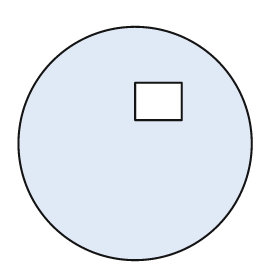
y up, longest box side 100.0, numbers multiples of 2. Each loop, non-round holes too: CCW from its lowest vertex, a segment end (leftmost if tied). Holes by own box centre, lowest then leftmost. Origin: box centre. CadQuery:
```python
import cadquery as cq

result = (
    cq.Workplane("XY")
    .moveTo(0.0, 0.0)
    .circle(50.0)
    .moveTo(0.0, 10.0)
    .lineTo(20.0, 10.0)
    .lineTo(20.0, 26.0)
    .lineTo(0.0, 26.0)
    .close()
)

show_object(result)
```